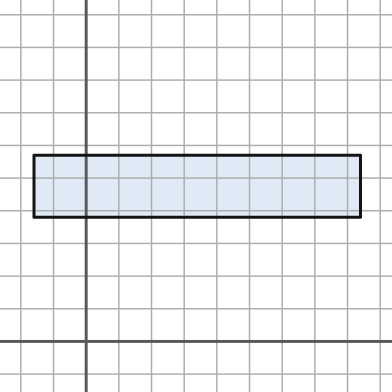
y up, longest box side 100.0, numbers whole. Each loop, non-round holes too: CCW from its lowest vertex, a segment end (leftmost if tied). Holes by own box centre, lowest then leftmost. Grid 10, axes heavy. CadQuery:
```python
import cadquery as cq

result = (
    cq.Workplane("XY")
    .moveTo(-16.0, 38.0)
    .lineTo(84.0, 38.0)
    .lineTo(84.0, 57.0)
    .lineTo(-16.0, 57.0)
    .close()
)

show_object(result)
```